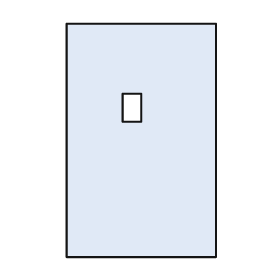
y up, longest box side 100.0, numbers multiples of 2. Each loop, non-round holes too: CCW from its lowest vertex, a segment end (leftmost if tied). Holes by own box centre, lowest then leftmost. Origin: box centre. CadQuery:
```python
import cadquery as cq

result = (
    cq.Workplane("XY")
    .moveTo(-32.0, -50.0)
    .lineTo(32.0, -50.0)
    .lineTo(32.0, 50.0)
    .lineTo(-32.0, 50.0)
    .close()
    .moveTo(-8.0, 8.0)
    .lineTo(0.0, 8.0)
    .lineTo(0.0, 20.0)
    .lineTo(-8.0, 20.0)
    .close()
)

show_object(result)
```